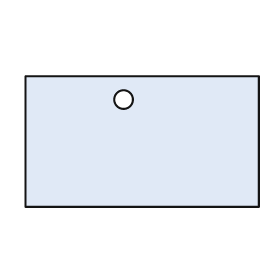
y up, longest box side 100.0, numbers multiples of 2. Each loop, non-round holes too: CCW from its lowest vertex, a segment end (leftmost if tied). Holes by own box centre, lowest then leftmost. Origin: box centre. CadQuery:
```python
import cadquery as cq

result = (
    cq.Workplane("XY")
    .moveTo(-50.0, -28.0)
    .lineTo(50.0, -28.0)
    .lineTo(50.0, 28.0)
    .lineTo(-50.0, 28.0)
    .close()
    .moveTo(-8.0, 18.0)
    .circle(4.0)
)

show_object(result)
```